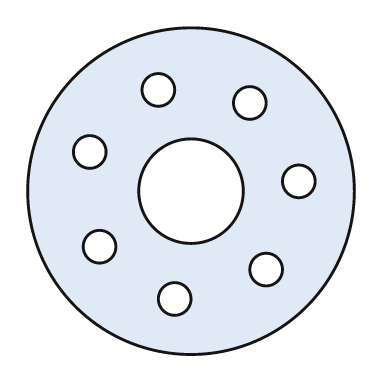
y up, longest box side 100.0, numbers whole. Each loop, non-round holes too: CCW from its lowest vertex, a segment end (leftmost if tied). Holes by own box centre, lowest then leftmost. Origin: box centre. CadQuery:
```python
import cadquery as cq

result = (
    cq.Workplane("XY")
    .moveTo(0.0, 0.0)
    .circle(50.0)
    .moveTo(-5.0, -33.0)
    .circle(5.0)
    .moveTo(23.0, -24.0)
    .circle(5.0)
    .moveTo(-28.0, -17.0)
    .circle(5.0)
    .moveTo(0.0, 0.0)
    .circle(16.0)
    .moveTo(33.0, 3.0)
    .circle(5.0)
    .moveTo(-31.0, 12.0)
    .circle(5.0)
    .moveTo(18.0, 27.0)
    .circle(5.0)
    .moveTo(-10.0, 31.0)
    .circle(5.0)
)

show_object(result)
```